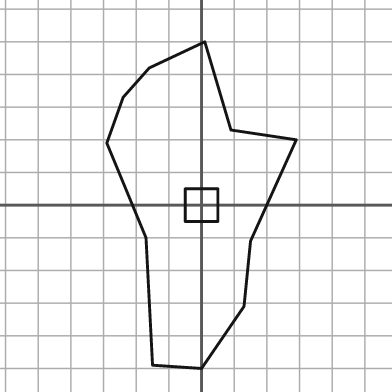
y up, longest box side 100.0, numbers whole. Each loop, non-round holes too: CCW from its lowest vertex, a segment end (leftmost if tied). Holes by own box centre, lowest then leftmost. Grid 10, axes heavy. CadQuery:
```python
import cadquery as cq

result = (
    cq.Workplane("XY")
    .moveTo(0.0, -50.0)
    .lineTo(13.0, -31.0)
    .lineTo(15.0, -11.0)
    .lineTo(29.0, 20.0)
    .lineTo(9.0, 23.0)
    .lineTo(1.0, 50.0)
    .lineTo(-16.0, 42.0)
    .lineTo(-24.0, 33.0)
    .lineTo(-29.0, 19.0)
    .lineTo(-17.0, -10.0)
    .lineTo(-15.0, -49.0)
    .close()
    .moveTo(-5.0, -5.0)
    .lineTo(5.0, -5.0)
    .lineTo(5.0, 5.0)
    .lineTo(-5.0, 5.0)
    .close()
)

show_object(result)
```